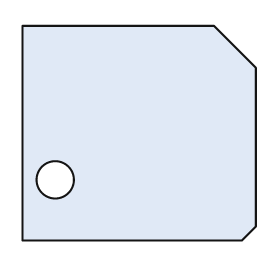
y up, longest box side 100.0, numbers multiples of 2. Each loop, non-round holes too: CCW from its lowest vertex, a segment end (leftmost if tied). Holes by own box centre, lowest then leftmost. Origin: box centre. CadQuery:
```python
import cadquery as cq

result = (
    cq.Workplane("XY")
    .moveTo(-50.0, -46.0)
    .lineTo(44.0, -46.0)
    .lineTo(50.0, -40.0)
    .lineTo(50.0, 28.0)
    .lineTo(32.0, 46.0)
    .lineTo(-50.0, 46.0)
    .close()
    .moveTo(-36.0, -20.0)
    .circle(8.0)
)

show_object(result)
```